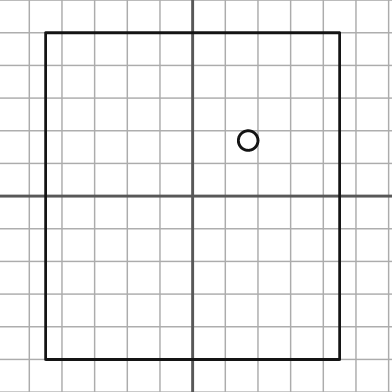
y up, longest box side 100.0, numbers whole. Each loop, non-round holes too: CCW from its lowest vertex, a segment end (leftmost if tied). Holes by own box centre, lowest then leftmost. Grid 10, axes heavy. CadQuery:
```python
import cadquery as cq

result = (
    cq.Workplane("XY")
    .moveTo(-45.0, -50.0)
    .lineTo(45.0, -50.0)
    .lineTo(45.0, 50.0)
    .lineTo(-45.0, 50.0)
    .close()
    .moveTo(17.0, 17.0)
    .circle(3.0)
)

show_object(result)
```